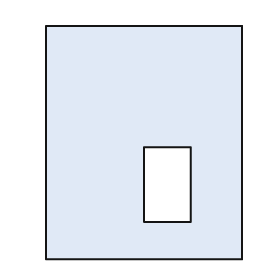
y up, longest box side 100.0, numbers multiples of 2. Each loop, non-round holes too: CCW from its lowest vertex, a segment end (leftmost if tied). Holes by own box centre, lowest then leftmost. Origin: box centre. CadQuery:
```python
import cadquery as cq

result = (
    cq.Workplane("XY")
    .moveTo(-42.0, -50.0)
    .lineTo(42.0, -50.0)
    .lineTo(42.0, 50.0)
    .lineTo(-42.0, 50.0)
    .close()
    .moveTo(0.0, -34.0)
    .lineTo(20.0, -34.0)
    .lineTo(20.0, -2.0)
    .lineTo(0.0, -2.0)
    .close()
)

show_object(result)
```